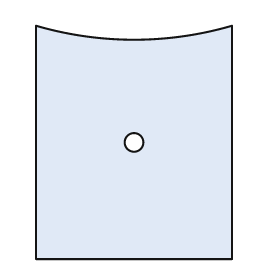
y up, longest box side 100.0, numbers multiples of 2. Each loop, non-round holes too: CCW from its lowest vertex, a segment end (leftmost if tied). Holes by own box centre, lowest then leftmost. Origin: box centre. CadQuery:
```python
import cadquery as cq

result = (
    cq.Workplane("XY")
    .moveTo(-42.0, -50.0)
    .lineTo(42.0, -50.0)
    .lineTo(42.0, 50.0)
    .threePointArc((0.0, 44.0), (-42.0, 50.0))
    .close()
    .moveTo(0.0, 0.0)
    .circle(4.0)
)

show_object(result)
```